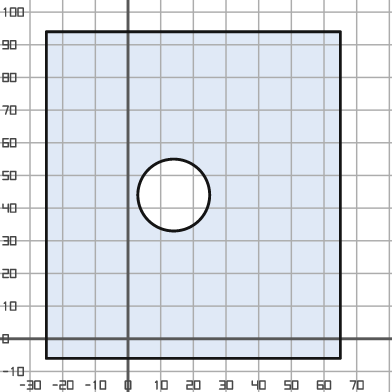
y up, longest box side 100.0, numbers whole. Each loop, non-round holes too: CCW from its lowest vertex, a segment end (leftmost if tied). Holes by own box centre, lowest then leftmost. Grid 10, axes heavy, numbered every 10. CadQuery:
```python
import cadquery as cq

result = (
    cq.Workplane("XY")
    .moveTo(-25.0, -6.0)
    .lineTo(65.0, -6.0)
    .lineTo(65.0, 94.0)
    .lineTo(-25.0, 94.0)
    .close()
    .moveTo(14.0, 44.0)
    .circle(11.0)
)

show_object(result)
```